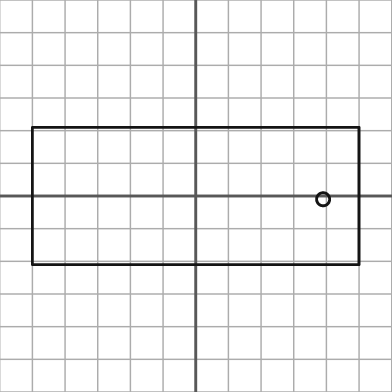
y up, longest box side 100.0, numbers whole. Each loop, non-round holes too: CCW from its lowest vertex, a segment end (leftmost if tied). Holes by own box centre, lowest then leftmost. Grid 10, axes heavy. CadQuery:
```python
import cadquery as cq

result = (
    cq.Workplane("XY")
    .moveTo(-50.0, -21.0)
    .lineTo(50.0, -21.0)
    .lineTo(50.0, 21.0)
    .lineTo(-50.0, 21.0)
    .close()
    .moveTo(39.0, -1.0)
    .circle(2.0)
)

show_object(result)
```